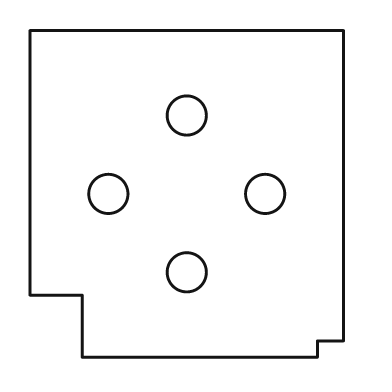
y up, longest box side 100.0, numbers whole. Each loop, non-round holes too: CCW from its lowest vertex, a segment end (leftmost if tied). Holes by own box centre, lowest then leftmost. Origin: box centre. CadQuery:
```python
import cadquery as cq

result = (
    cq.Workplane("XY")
    .moveTo(-32.0, -50.0)
    .lineTo(40.0, -50.0)
    .lineTo(40.0, -45.0)
    .lineTo(48.0, -45.0)
    .lineTo(48.0, 50.0)
    .lineTo(-48.0, 50.0)
    .lineTo(-48.0, -31.0)
    .lineTo(-32.0, -31.0)
    .close()
    .moveTo(0.0, -24.0)
    .circle(6.0)
    .moveTo(-24.0, 0.0)
    .circle(6.0)
    .moveTo(24.0, 0.0)
    .circle(6.0)
    .moveTo(0.0, 24.0)
    .circle(6.0)
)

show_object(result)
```